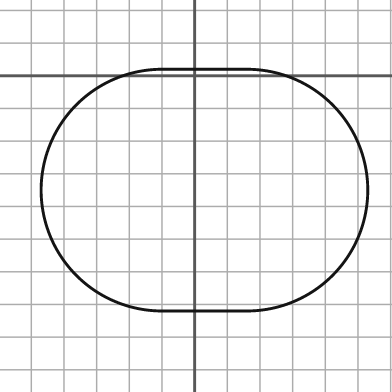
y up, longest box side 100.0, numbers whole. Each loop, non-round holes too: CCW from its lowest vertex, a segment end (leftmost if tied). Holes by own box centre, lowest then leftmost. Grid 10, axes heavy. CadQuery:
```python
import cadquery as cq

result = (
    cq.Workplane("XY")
    .moveTo(-10.0, -72.0)
    .lineTo(16.0, -72.0)
    .threePointArc((53.0, -35.0), (16.0, 2.0))
    .lineTo(-10.0, 2.0)
    .threePointArc((-47.0, -35.0), (-10.0, -72.0))
    .close()
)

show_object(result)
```